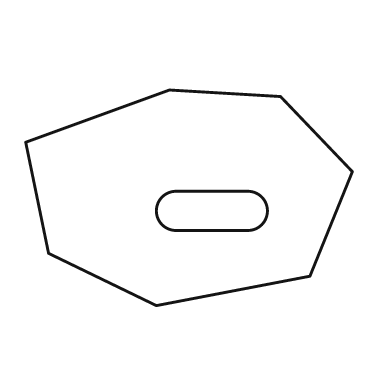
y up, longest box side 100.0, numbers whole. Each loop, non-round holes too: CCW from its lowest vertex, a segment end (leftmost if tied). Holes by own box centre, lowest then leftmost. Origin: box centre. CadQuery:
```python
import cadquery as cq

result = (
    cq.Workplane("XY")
    .moveTo(-10.0, -33.0)
    .lineTo(37.0, -24.0)
    .lineTo(50.0, 8.0)
    .lineTo(28.0, 31.0)
    .lineTo(-6.0, 33.0)
    .lineTo(-50.0, 17.0)
    .lineTo(-43.0, -17.0)
    .close()
    .moveTo(-4.0, -10.0)
    .lineTo(18.0, -10.0)
    .threePointArc((24.0, -4.0), (18.0, 2.0))
    .lineTo(-4.0, 2.0)
    .threePointArc((-10.0, -4.0), (-4.0, -10.0))
    .close()
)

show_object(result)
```